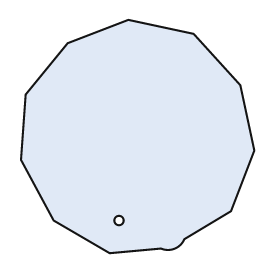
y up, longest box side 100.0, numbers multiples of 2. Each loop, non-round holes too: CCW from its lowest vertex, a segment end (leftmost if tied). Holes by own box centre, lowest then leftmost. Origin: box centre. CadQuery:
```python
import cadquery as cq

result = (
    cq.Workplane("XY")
    .moveTo(-12.0, -50.0)
    .lineTo(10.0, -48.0)
    .threePointArc((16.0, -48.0), (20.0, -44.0))
    .lineTo(40.0, -32.0)
    .lineTo(50.0, -6.0)
    .lineTo(44.0, 22.0)
    .lineTo(24.0, 44.0)
    .lineTo(-4.0, 50.0)
    .lineTo(-30.0, 40.0)
    .lineTo(-48.0, 18.0)
    .lineTo(-50.0, -10.0)
    .lineTo(-36.0, -36.0)
    .close()
    .moveTo(-8.0, -36.0)
    .circle(2.0)
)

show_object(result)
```